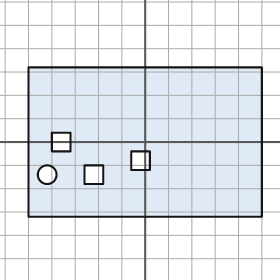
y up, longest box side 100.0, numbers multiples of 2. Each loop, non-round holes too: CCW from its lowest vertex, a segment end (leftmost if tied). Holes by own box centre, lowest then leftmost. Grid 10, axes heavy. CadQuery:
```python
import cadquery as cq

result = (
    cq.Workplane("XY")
    .moveTo(-50.0, -32.0)
    .lineTo(50.0, -32.0)
    .lineTo(50.0, 32.0)
    .lineTo(-50.0, 32.0)
    .close()
    .moveTo(-42.0, -14.0)
    .circle(4.0)
    .moveTo(-26.0, -18.0)
    .lineTo(-18.0, -18.0)
    .lineTo(-18.0, -10.0)
    .lineTo(-26.0, -10.0)
    .close()
    .moveTo(-6.0, -12.0)
    .lineTo(2.0, -12.0)
    .lineTo(2.0, -4.0)
    .lineTo(-6.0, -4.0)
    .close()
    .moveTo(-40.0, -4.0)
    .lineTo(-32.0, -4.0)
    .lineTo(-32.0, 4.0)
    .lineTo(-40.0, 4.0)
    .close()
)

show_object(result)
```